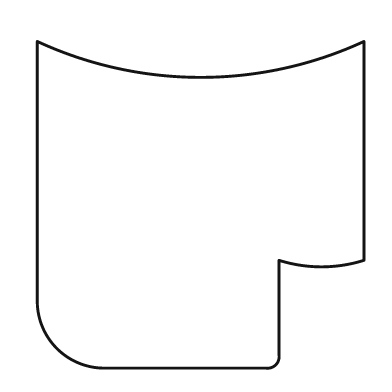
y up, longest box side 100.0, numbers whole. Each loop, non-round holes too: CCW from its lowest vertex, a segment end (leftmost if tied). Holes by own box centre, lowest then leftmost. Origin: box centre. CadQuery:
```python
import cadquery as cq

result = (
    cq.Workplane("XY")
    .moveTo(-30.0, -50.0)
    .lineTo(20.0, -50.0)
    .threePointArc((23.0, -49.0), (24.0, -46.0))
    .lineTo(24.0, -17.0)
    .threePointArc((37.0, -19.0), (50.0, -17.0))
    .lineTo(50.0, 50.0)
    .threePointArc((0.0, 39.0), (-50.0, 50.0))
    .lineTo(-50.0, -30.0)
    .threePointArc((-44.0, -44.0), (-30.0, -50.0))
    .close()
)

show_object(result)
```